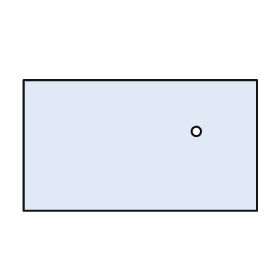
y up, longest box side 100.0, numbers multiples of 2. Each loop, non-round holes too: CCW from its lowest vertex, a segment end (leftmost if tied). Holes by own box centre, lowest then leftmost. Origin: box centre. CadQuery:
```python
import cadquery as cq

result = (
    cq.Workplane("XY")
    .moveTo(-50.0, -28.0)
    .lineTo(50.0, -28.0)
    .lineTo(50.0, 28.0)
    .lineTo(-50.0, 28.0)
    .close()
    .moveTo(24.0, 6.0)
    .circle(2.0)
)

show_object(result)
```